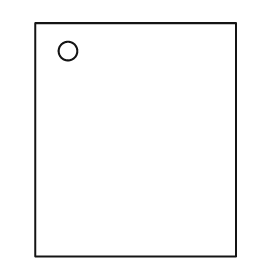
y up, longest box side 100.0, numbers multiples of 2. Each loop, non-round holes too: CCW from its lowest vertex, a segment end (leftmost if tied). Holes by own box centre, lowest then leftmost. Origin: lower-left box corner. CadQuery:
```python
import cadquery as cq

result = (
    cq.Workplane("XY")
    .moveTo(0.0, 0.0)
    .lineTo(86.0, 0.0)
    .lineTo(86.0, 100.0)
    .lineTo(0.0, 100.0)
    .close()
    .moveTo(14.0, 88.0)
    .circle(4.0)
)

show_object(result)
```